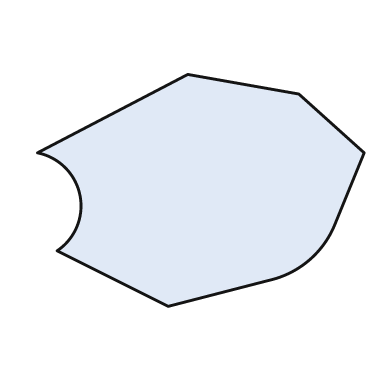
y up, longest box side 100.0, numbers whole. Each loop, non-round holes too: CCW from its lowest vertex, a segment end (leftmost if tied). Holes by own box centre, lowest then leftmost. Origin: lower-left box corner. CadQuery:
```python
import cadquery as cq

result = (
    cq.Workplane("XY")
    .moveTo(40.0, 0.0)
    .lineTo(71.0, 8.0)
    .threePointArc((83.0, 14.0), (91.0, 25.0))
    .lineTo(100.0, 47.0)
    .lineTo(80.0, 65.0)
    .lineTo(46.0, 71.0)
    .lineTo(0.0, 47.0)
    .threePointArc((13.0, 34.0), (6.0, 17.0))
    .close()
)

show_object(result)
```